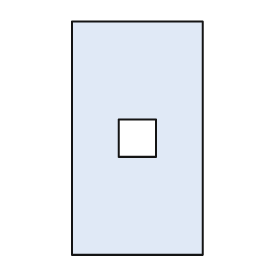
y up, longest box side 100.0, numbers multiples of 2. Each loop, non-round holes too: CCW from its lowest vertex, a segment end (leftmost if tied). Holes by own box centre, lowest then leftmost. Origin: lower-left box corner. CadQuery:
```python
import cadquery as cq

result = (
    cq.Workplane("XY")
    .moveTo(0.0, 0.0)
    .lineTo(56.0, 0.0)
    .lineTo(56.0, 100.0)
    .lineTo(0.0, 100.0)
    .close()
    .moveTo(20.0, 42.0)
    .lineTo(36.0, 42.0)
    .lineTo(36.0, 58.0)
    .lineTo(20.0, 58.0)
    .close()
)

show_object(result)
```